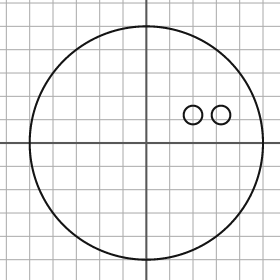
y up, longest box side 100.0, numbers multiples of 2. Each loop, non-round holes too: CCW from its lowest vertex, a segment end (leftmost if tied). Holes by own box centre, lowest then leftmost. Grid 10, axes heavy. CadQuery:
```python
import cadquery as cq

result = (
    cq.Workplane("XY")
    .moveTo(0.0, 0.0)
    .circle(50.0)
    .moveTo(20.0, 12.0)
    .circle(4.0)
    .moveTo(32.0, 12.0)
    .circle(4.0)
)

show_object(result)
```